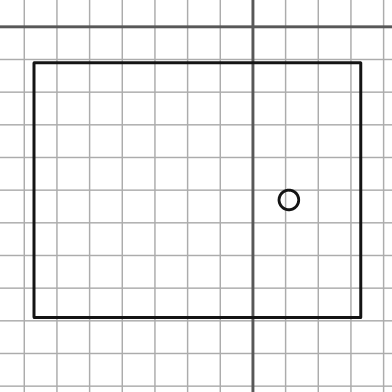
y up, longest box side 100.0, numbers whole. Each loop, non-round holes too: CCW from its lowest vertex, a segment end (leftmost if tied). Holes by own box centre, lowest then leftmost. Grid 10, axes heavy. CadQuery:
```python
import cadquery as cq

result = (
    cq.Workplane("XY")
    .moveTo(-67.0, -89.0)
    .lineTo(33.0, -89.0)
    .lineTo(33.0, -11.0)
    .lineTo(-67.0, -11.0)
    .close()
    .moveTo(11.0, -53.0)
    .circle(3.0)
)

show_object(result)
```